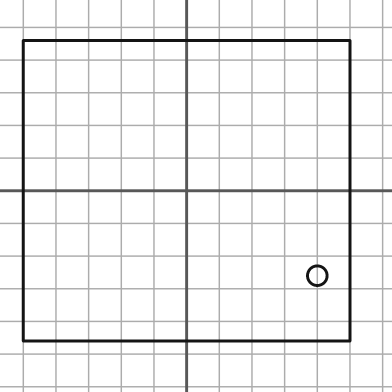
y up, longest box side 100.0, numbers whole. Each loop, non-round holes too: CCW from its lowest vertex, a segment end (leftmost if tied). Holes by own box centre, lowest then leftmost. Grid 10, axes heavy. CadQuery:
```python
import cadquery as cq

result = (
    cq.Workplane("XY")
    .moveTo(-50.0, -46.0)
    .lineTo(50.0, -46.0)
    .lineTo(50.0, 46.0)
    .lineTo(-50.0, 46.0)
    .close()
    .moveTo(40.0, -26.0)
    .circle(3.0)
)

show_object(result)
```